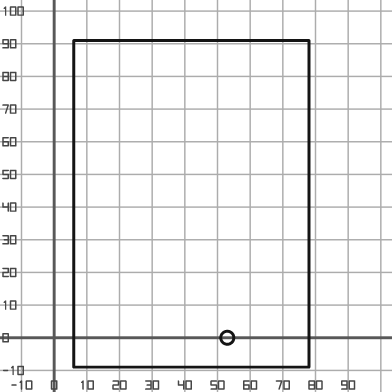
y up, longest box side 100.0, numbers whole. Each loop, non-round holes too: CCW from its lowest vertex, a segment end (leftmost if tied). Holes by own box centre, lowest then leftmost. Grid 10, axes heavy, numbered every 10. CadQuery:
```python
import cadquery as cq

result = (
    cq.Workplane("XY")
    .moveTo(6.0, -9.0)
    .lineTo(78.0, -9.0)
    .lineTo(78.0, 91.0)
    .lineTo(6.0, 91.0)
    .close()
    .moveTo(53.0, 0.0)
    .circle(2.0)
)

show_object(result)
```